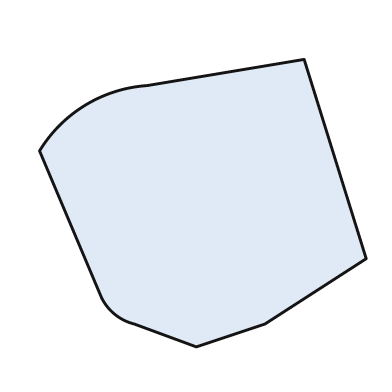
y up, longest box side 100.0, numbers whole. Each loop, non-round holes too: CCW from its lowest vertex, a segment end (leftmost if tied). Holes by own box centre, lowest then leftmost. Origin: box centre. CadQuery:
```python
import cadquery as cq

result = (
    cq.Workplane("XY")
    .moveTo(-2.0, -44.0)
    .lineTo(19.0, -37.0)
    .lineTo(50.0, -17.0)
    .lineTo(31.0, 44.0)
    .lineTo(-17.0, 36.0)
    .threePointArc((-36.0, 30.0), (-50.0, 16.0))
    .lineTo(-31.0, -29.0)
    .threePointArc((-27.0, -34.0), (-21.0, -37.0))
    .close()
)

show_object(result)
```